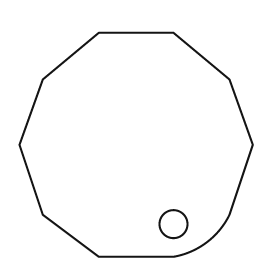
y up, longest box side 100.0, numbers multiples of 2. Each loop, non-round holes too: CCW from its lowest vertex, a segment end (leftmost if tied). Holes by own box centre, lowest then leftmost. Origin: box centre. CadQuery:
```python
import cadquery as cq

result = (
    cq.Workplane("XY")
    .moveTo(-16.0, -48.0)
    .lineTo(16.0, -48.0)
    .threePointArc((30.0, -42.0), (40.0, -30.0))
    .lineTo(50.0, 0.0)
    .lineTo(40.0, 28.0)
    .lineTo(16.0, 48.0)
    .lineTo(-16.0, 48.0)
    .lineTo(-40.0, 28.0)
    .lineTo(-50.0, 0.0)
    .lineTo(-40.0, -30.0)
    .close()
    .moveTo(16.0, -34.0)
    .circle(6.0)
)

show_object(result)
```